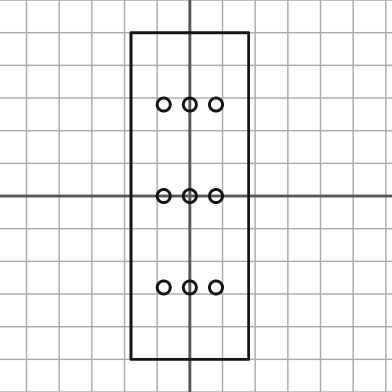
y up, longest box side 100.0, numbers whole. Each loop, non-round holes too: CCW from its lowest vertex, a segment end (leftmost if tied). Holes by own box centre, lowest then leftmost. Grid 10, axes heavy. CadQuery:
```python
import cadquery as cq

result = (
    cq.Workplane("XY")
    .moveTo(-18.0, -50.0)
    .lineTo(18.0, -50.0)
    .lineTo(18.0, 50.0)
    .lineTo(-18.0, 50.0)
    .close()
    .moveTo(-8.0, -28.0)
    .circle(2.0)
    .moveTo(0.0, -28.0)
    .circle(2.0)
    .moveTo(8.0, -28.0)
    .circle(2.0)
    .moveTo(-8.0, 0.0)
    .circle(2.0)
    .moveTo(0.0, 0.0)
    .circle(2.0)
    .moveTo(8.0, 0.0)
    .circle(2.0)
    .moveTo(-8.0, 28.0)
    .circle(2.0)
    .moveTo(0.0, 28.0)
    .circle(2.0)
    .moveTo(8.0, 28.0)
    .circle(2.0)
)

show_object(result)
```